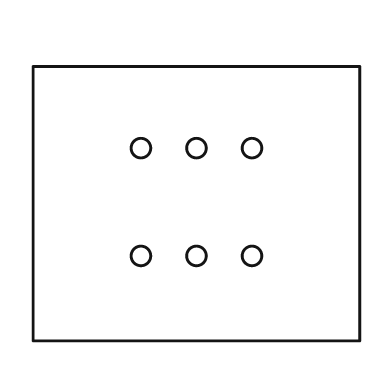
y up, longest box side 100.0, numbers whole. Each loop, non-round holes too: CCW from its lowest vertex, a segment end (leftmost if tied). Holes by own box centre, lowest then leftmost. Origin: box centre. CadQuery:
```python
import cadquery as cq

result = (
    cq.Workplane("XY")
    .moveTo(-50.0, -42.0)
    .lineTo(50.0, -42.0)
    .lineTo(50.0, 42.0)
    .lineTo(-50.0, 42.0)
    .close()
    .moveTo(-17.0, -16.0)
    .circle(3.0)
    .moveTo(0.0, -16.0)
    .circle(3.0)
    .moveTo(17.0, -16.0)
    .circle(3.0)
    .moveTo(-17.0, 17.0)
    .circle(3.0)
    .moveTo(0.0, 17.0)
    .circle(3.0)
    .moveTo(17.0, 17.0)
    .circle(3.0)
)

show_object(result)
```